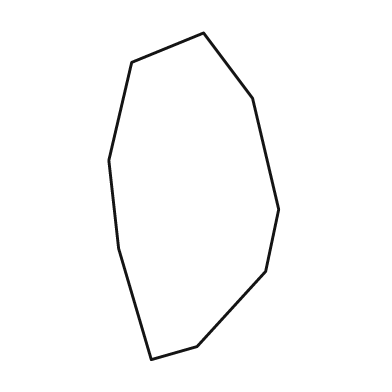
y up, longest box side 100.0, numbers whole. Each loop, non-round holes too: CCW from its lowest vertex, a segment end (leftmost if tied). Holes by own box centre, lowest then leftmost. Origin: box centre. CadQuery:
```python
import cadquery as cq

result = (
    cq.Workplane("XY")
    .moveTo(-13.0, -50.0)
    .lineTo(1.0, -46.0)
    .lineTo(22.0, -23.0)
    .lineTo(26.0, -4.0)
    .lineTo(18.0, 30.0)
    .lineTo(3.0, 50.0)
    .lineTo(-19.0, 41.0)
    .lineTo(-26.0, 11.0)
    .lineTo(-23.0, -16.0)
    .close()
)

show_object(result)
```